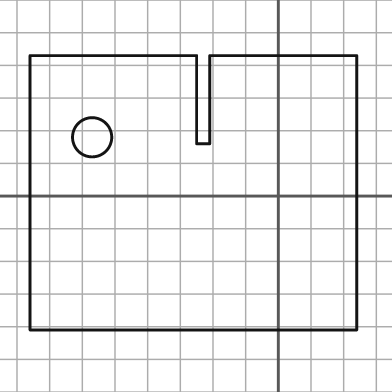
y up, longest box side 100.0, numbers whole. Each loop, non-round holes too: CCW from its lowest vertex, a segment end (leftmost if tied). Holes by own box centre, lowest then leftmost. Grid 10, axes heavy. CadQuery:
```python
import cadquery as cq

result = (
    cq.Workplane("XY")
    .moveTo(-76.0, -41.0)
    .lineTo(24.0, -41.0)
    .lineTo(24.0, 43.0)
    .lineTo(-21.0, 43.0)
    .lineTo(-21.0, 16.0)
    .lineTo(-25.0, 16.0)
    .lineTo(-25.0, 43.0)
    .lineTo(-76.0, 43.0)
    .close()
    .moveTo(-57.0, 18.0)
    .circle(6.0)
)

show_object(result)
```